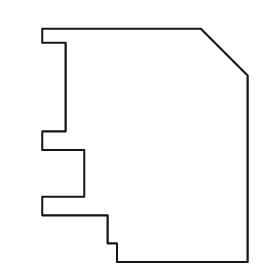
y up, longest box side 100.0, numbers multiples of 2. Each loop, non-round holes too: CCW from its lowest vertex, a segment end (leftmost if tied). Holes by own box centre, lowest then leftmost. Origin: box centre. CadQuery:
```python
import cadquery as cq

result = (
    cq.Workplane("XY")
    .moveTo(-12.0, -50.0)
    .lineTo(44.0, -50.0)
    .lineTo(44.0, 30.0)
    .lineTo(24.0, 50.0)
    .lineTo(-44.0, 50.0)
    .lineTo(-44.0, 44.0)
    .lineTo(-34.0, 44.0)
    .lineTo(-34.0, 6.0)
    .lineTo(-44.0, 6.0)
    .lineTo(-44.0, -2.0)
    .lineTo(-26.0, -2.0)
    .lineTo(-26.0, -22.0)
    .lineTo(-44.0, -22.0)
    .lineTo(-44.0, -30.0)
    .lineTo(-16.0, -30.0)
    .lineTo(-16.0, -42.0)
    .lineTo(-12.0, -42.0)
    .close()
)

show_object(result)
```